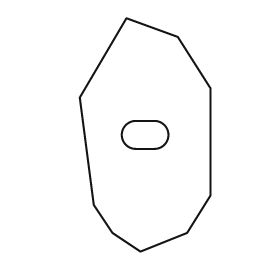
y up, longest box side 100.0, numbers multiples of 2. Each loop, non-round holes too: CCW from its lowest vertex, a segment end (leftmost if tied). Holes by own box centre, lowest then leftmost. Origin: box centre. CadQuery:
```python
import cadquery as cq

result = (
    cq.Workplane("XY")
    .moveTo(-2.0, -50.0)
    .lineTo(18.0, -42.0)
    .lineTo(28.0, -26.0)
    .lineTo(28.0, 20.0)
    .lineTo(14.0, 42.0)
    .lineTo(-8.0, 50.0)
    .lineTo(-28.0, 16.0)
    .lineTo(-22.0, -30.0)
    .lineTo(-14.0, -42.0)
    .close()
    .moveTo(-4.0, -6.0)
    .lineTo(4.0, -6.0)
    .threePointArc((10.0, 0.0), (4.0, 6.0))
    .lineTo(-4.0, 6.0)
    .threePointArc((-10.0, 0.0), (-4.0, -6.0))
    .close()
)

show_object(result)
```